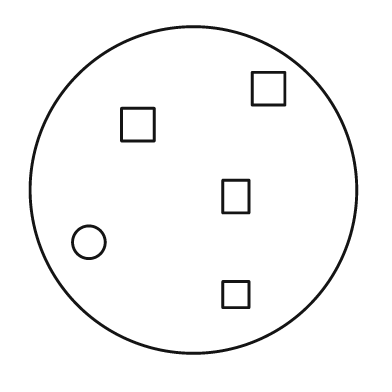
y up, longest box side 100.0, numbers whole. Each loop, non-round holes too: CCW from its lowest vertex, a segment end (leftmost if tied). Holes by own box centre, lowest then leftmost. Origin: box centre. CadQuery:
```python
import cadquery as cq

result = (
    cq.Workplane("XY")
    .moveTo(0.0, 0.0)
    .circle(50.0)
    .moveTo(9.0, -36.0)
    .lineTo(17.0, -36.0)
    .lineTo(17.0, -28.0)
    .lineTo(9.0, -28.0)
    .close()
    .moveTo(-32.0, -16.0)
    .circle(5.0)
    .moveTo(9.0, -7.0)
    .lineTo(17.0, -7.0)
    .lineTo(17.0, 3.0)
    .lineTo(9.0, 3.0)
    .close()
    .moveTo(-22.0, 15.0)
    .lineTo(-12.0, 15.0)
    .lineTo(-12.0, 25.0)
    .lineTo(-22.0, 25.0)
    .close()
    .moveTo(18.0, 26.0)
    .lineTo(28.0, 26.0)
    .lineTo(28.0, 36.0)
    .lineTo(18.0, 36.0)
    .close()
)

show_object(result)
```